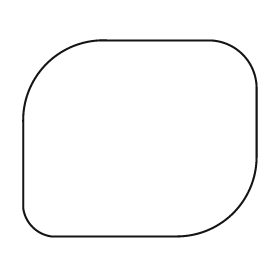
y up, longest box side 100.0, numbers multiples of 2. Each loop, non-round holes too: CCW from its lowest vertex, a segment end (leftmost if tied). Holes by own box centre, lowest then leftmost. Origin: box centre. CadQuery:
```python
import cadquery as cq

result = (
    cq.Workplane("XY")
    .moveTo(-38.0, -42.0)
    .lineTo(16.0, -42.0)
    .threePointArc((40.0, -32.0), (50.0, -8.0))
    .lineTo(50.0, 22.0)
    .threePointArc((44.0, 36.0), (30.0, 42.0))
    .lineTo(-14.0, 42.0)
    .threePointArc((-40.0, 32.0), (-50.0, 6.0))
    .lineTo(-50.0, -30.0)
    .threePointArc((-46.0, -38.0), (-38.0, -42.0))
    .close()
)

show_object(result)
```